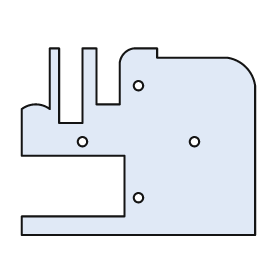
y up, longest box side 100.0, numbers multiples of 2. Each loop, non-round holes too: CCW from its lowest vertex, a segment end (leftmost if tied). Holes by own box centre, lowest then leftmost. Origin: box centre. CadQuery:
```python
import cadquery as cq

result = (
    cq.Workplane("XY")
    .moveTo(-50.0, -40.0)
    .lineTo(50.0, -40.0)
    .lineTo(50.0, 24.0)
    .threePointArc((46.0, 32.0), (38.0, 36.0))
    .lineTo(8.0, 36.0)
    .lineTo(8.0, 40.0)
    .lineTo(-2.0, 40.0)
    .threePointArc((-6.0, 38.0), (-8.0, 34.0))
    .lineTo(-8.0, 16.0)
    .lineTo(-18.0, 16.0)
    .lineTo(-18.0, 40.0)
    .lineTo(-24.0, 40.0)
    .lineTo(-24.0, 8.0)
    .lineTo(-34.0, 8.0)
    .lineTo(-34.0, 40.0)
    .lineTo(-38.0, 40.0)
    .lineTo(-38.0, 14.0)
    .threePointArc((-44.0, 16.0), (-50.0, 14.0))
    .lineTo(-50.0, -6.0)
    .lineTo(-6.0, -6.0)
    .lineTo(-6.0, -32.0)
    .lineTo(-50.0, -32.0)
    .close()
    .moveTo(0.0, -24.0)
    .circle(2.0)
    .moveTo(-24.0, 0.0)
    .circle(2.0)
    .moveTo(24.0, 0.0)
    .circle(2.0)
    .moveTo(0.0, 24.0)
    .circle(2.0)
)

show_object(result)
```